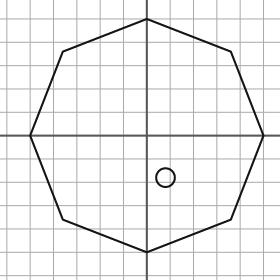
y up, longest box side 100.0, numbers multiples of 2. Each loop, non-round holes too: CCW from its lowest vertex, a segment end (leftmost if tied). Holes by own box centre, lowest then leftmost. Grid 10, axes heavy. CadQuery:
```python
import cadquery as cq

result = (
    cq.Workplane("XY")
    .moveTo(0.0, -50.0)
    .lineTo(36.0, -36.0)
    .lineTo(50.0, 0.0)
    .lineTo(36.0, 36.0)
    .lineTo(0.0, 50.0)
    .lineTo(-36.0, 36.0)
    .lineTo(-50.0, 0.0)
    .lineTo(-36.0, -36.0)
    .close()
    .moveTo(8.0, -18.0)
    .circle(4.0)
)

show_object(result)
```